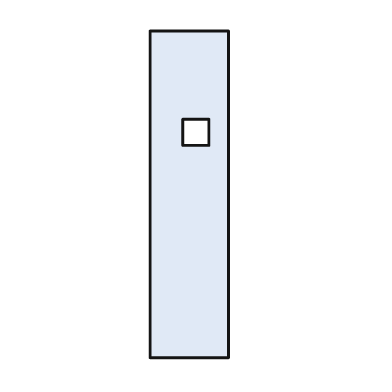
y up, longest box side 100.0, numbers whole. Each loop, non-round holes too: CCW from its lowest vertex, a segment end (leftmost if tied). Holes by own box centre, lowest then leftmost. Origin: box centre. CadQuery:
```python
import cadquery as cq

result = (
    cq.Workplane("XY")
    .moveTo(-12.0, -50.0)
    .lineTo(12.0, -50.0)
    .lineTo(12.0, 50.0)
    .lineTo(-12.0, 50.0)
    .close()
    .moveTo(-2.0, 15.0)
    .lineTo(6.0, 15.0)
    .lineTo(6.0, 23.0)
    .lineTo(-2.0, 23.0)
    .close()
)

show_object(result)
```